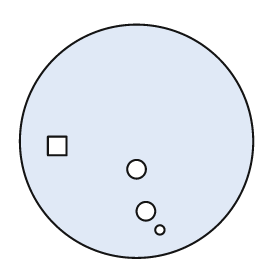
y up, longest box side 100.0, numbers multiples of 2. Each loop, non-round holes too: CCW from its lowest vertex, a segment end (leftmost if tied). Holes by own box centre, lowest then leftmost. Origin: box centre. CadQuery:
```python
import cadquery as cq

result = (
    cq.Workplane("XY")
    .moveTo(0.0, 0.0)
    .circle(50.0)
    .moveTo(10.0, -38.0)
    .circle(2.0)
    .moveTo(4.0, -30.0)
    .circle(4.0)
    .moveTo(0.0, -12.0)
    .circle(4.0)
    .moveTo(-38.0, -6.0)
    .lineTo(-30.0, -6.0)
    .lineTo(-30.0, 2.0)
    .lineTo(-38.0, 2.0)
    .close()
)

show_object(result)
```